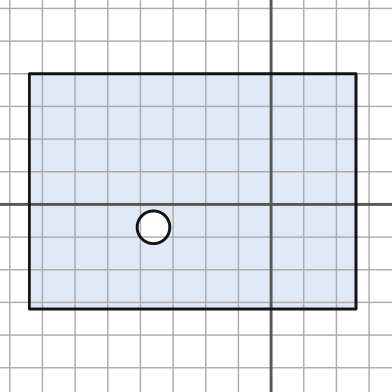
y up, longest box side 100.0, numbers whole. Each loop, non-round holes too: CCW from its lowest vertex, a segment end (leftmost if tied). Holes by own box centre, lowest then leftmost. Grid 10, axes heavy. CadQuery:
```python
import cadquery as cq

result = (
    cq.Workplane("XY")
    .moveTo(-74.0, -32.0)
    .lineTo(26.0, -32.0)
    .lineTo(26.0, 40.0)
    .lineTo(-74.0, 40.0)
    .close()
    .moveTo(-36.0, -7.0)
    .circle(5.0)
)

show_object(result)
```